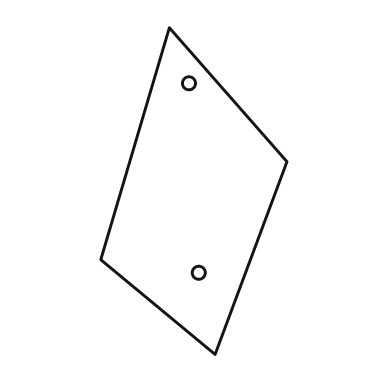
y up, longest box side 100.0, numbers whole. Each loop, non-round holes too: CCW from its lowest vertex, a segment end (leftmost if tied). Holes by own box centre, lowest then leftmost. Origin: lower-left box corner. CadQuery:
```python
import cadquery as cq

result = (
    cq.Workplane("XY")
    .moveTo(35.0, 0.0)
    .lineTo(57.0, 59.0)
    .lineTo(21.0, 100.0)
    .lineTo(0.0, 29.0)
    .close()
    .moveTo(30.0, 25.0)
    .circle(2.0)
    .moveTo(27.0, 83.0)
    .circle(2.0)
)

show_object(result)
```